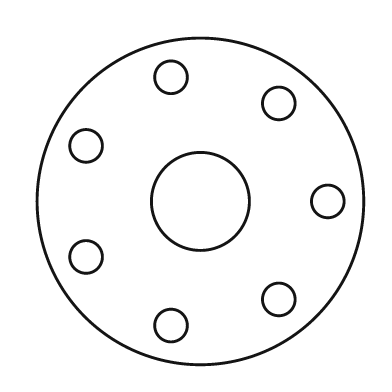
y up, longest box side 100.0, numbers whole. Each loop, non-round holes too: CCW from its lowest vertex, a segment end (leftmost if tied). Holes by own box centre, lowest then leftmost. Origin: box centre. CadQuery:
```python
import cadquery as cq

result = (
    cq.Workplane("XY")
    .moveTo(0.0, 0.0)
    .circle(50.0)
    .moveTo(-9.0, -38.0)
    .circle(5.0)
    .moveTo(24.0, -30.0)
    .circle(5.0)
    .moveTo(-35.0, -17.0)
    .circle(5.0)
    .moveTo(0.0, 0.0)
    .circle(15.0)
    .moveTo(39.0, 0.0)
    .circle(5.0)
    .moveTo(-35.0, 17.0)
    .circle(5.0)
    .moveTo(24.0, 30.0)
    .circle(5.0)
    .moveTo(-9.0, 38.0)
    .circle(5.0)
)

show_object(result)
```